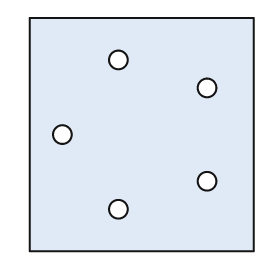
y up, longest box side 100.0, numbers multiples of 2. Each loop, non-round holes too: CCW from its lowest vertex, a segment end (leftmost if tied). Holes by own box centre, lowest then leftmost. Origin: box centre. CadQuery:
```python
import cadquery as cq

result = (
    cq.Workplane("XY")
    .moveTo(-48.0, -50.0)
    .lineTo(48.0, -50.0)
    .lineTo(48.0, 50.0)
    .lineTo(-48.0, 50.0)
    .close()
    .moveTo(-10.0, -32.0)
    .circle(4.0)
    .moveTo(28.0, -20.0)
    .circle(4.0)
    .moveTo(-34.0, 0.0)
    .circle(4.0)
    .moveTo(28.0, 20.0)
    .circle(4.0)
    .moveTo(-10.0, 32.0)
    .circle(4.0)
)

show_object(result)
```